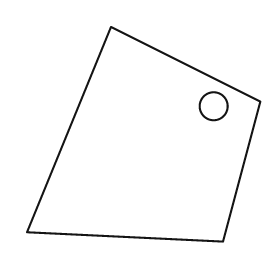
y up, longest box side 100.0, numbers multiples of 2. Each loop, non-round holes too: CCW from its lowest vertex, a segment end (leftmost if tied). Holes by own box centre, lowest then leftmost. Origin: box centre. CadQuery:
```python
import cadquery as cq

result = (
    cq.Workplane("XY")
    .moveTo(34.0, -46.0)
    .lineTo(50.0, 14.0)
    .lineTo(-14.0, 46.0)
    .lineTo(-50.0, -42.0)
    .close()
    .moveTo(30.0, 12.0)
    .circle(6.0)
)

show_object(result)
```